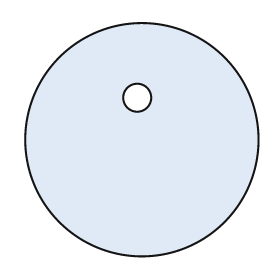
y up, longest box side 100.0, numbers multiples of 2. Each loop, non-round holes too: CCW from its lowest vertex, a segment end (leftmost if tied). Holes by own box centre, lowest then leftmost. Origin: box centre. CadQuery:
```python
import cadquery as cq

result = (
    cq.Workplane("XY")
    .moveTo(0.0, 0.0)
    .circle(50.0)
    .moveTo(-2.0, 18.0)
    .circle(6.0)
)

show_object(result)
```